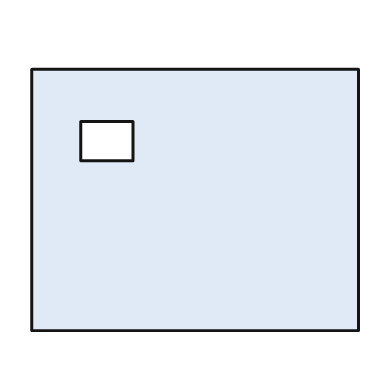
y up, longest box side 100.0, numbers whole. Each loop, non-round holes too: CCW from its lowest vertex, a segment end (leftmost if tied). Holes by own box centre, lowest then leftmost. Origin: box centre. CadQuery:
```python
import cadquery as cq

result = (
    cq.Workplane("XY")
    .moveTo(-50.0, -40.0)
    .lineTo(50.0, -40.0)
    .lineTo(50.0, 40.0)
    .lineTo(-50.0, 40.0)
    .close()
    .moveTo(-35.0, 12.0)
    .lineTo(-19.0, 12.0)
    .lineTo(-19.0, 24.0)
    .lineTo(-35.0, 24.0)
    .close()
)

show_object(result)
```